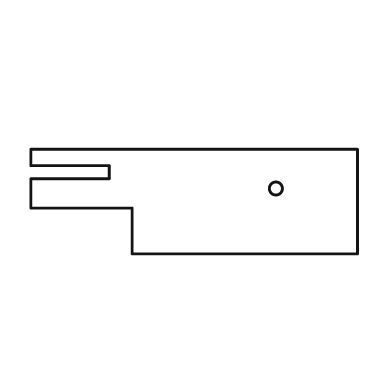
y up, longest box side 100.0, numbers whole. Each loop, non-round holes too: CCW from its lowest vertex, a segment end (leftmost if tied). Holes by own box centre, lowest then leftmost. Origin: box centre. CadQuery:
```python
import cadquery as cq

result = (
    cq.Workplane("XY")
    .moveTo(-19.0, -16.0)
    .lineTo(50.0, -16.0)
    .lineTo(50.0, 16.0)
    .lineTo(-50.0, 16.0)
    .lineTo(-50.0, 11.0)
    .lineTo(-26.0, 11.0)
    .lineTo(-26.0, 7.0)
    .lineTo(-50.0, 7.0)
    .lineTo(-50.0, -2.0)
    .lineTo(-19.0, -2.0)
    .close()
    .moveTo(25.0, 4.0)
    .circle(2.0)
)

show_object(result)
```